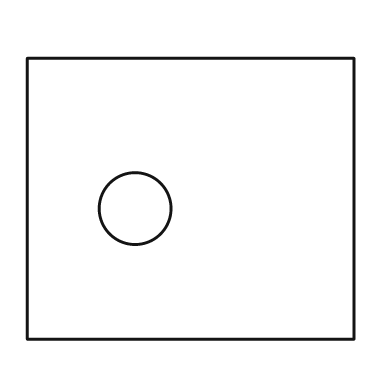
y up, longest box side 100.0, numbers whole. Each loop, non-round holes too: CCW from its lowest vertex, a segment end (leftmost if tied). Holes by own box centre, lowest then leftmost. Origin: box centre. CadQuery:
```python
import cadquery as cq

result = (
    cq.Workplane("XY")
    .moveTo(-50.0, -43.0)
    .lineTo(50.0, -43.0)
    .lineTo(50.0, 43.0)
    .lineTo(-50.0, 43.0)
    .close()
    .moveTo(-17.0, -3.0)
    .circle(11.0)
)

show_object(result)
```